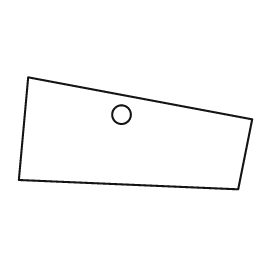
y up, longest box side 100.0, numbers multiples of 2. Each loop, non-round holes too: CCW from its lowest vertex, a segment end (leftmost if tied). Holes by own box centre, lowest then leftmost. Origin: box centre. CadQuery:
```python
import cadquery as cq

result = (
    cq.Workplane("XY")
    .moveTo(44.0, -24.0)
    .lineTo(50.0, 6.0)
    .lineTo(-46.0, 24.0)
    .lineTo(-50.0, -20.0)
    .close()
    .moveTo(-6.0, 8.0)
    .circle(4.0)
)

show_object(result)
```